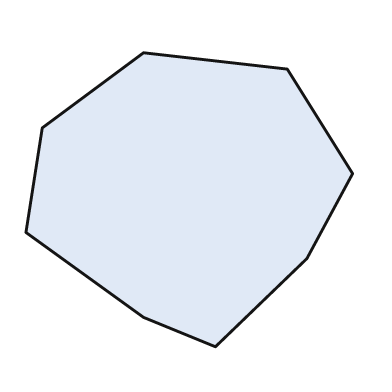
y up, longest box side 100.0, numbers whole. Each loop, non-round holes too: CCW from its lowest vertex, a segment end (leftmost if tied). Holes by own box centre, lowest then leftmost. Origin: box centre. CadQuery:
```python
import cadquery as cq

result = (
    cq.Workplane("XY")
    .moveTo(8.0, -45.0)
    .lineTo(36.0, -18.0)
    .lineTo(50.0, 8.0)
    .lineTo(30.0, 40.0)
    .lineTo(-14.0, 45.0)
    .lineTo(-45.0, 22.0)
    .lineTo(-50.0, -10.0)
    .lineTo(-14.0, -36.0)
    .close()
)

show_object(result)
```